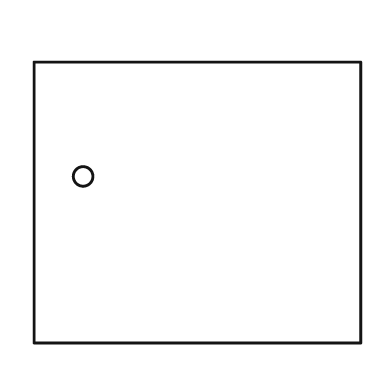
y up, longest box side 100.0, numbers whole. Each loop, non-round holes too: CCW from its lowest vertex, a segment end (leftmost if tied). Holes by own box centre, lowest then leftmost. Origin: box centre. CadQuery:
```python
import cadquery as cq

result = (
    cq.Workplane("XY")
    .moveTo(-50.0, -43.0)
    .lineTo(50.0, -43.0)
    .lineTo(50.0, 43.0)
    .lineTo(-50.0, 43.0)
    .close()
    .moveTo(-35.0, 8.0)
    .circle(3.0)
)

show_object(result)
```